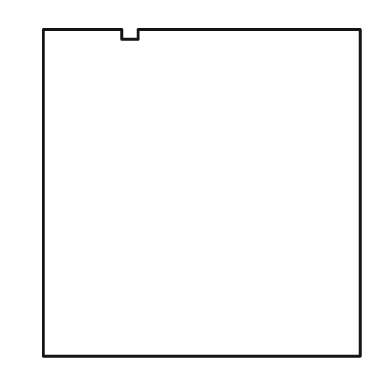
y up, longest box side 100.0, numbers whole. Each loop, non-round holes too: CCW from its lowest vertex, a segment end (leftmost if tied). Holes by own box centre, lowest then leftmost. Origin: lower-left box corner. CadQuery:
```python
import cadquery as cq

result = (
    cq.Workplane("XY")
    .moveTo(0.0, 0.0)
    .lineTo(97.0, 0.0)
    .lineTo(97.0, 100.0)
    .lineTo(29.0, 100.0)
    .lineTo(29.0, 97.0)
    .lineTo(24.0, 97.0)
    .lineTo(24.0, 100.0)
    .lineTo(0.0, 100.0)
    .close()
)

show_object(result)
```